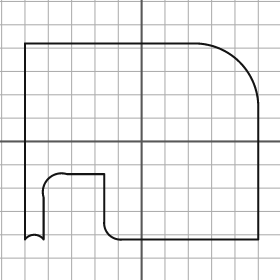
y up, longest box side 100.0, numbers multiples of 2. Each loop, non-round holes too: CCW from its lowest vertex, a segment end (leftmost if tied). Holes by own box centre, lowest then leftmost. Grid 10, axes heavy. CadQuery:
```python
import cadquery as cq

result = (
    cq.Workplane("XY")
    .moveTo(-50.0, -42.0)
    .threePointArc((-46.0, -40.0), (-42.0, -42.0))
    .lineTo(-42.0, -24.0)
    .threePointArc((-40.0, -16.0), (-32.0, -14.0))
    .lineTo(-16.0, -14.0)
    .lineTo(-16.0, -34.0)
    .threePointArc((-14.0, -40.0), (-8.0, -42.0))
    .lineTo(50.0, -42.0)
    .lineTo(50.0, 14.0)
    .threePointArc((42.0, 34.0), (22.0, 42.0))
    .lineTo(-50.0, 42.0)
    .close()
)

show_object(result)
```